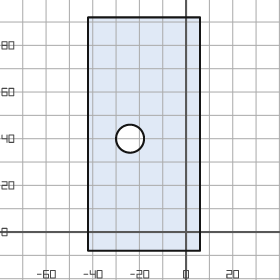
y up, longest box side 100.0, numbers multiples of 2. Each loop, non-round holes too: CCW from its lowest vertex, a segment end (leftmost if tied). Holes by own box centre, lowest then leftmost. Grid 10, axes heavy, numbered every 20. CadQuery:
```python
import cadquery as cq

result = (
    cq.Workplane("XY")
    .moveTo(-42.0, -8.0)
    .lineTo(6.0, -8.0)
    .lineTo(6.0, 92.0)
    .lineTo(-42.0, 92.0)
    .close()
    .moveTo(-24.0, 40.0)
    .circle(6.0)
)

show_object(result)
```